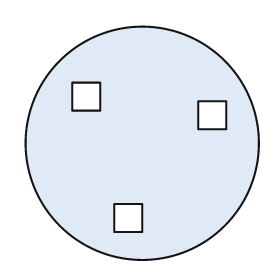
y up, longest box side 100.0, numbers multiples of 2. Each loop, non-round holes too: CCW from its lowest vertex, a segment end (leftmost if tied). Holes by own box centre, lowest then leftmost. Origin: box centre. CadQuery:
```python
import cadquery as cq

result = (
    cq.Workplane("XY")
    .moveTo(0.0, 0.0)
    .circle(50.0)
    .moveTo(-12.0, -38.0)
    .lineTo(0.0, -38.0)
    .lineTo(0.0, -26.0)
    .lineTo(-12.0, -26.0)
    .close()
    .moveTo(24.0, 6.0)
    .lineTo(36.0, 6.0)
    .lineTo(36.0, 18.0)
    .lineTo(24.0, 18.0)
    .close()
    .moveTo(-30.0, 14.0)
    .lineTo(-18.0, 14.0)
    .lineTo(-18.0, 26.0)
    .lineTo(-30.0, 26.0)
    .close()
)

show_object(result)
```